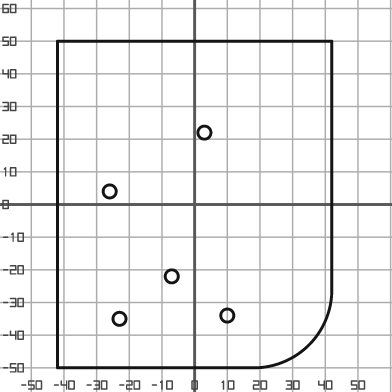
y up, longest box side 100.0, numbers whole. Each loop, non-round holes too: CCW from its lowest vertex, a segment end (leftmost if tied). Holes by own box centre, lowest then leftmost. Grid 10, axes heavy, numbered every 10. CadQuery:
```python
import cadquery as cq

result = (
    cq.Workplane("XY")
    .moveTo(-42.0, -50.0)
    .lineTo(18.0, -50.0)
    .threePointArc((35.0, -43.0), (42.0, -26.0))
    .lineTo(42.0, 50.0)
    .lineTo(-42.0, 50.0)
    .close()
    .moveTo(-23.0, -35.0)
    .circle(2.0)
    .moveTo(10.0, -34.0)
    .circle(2.0)
    .moveTo(-7.0, -22.0)
    .circle(2.0)
    .moveTo(-26.0, 4.0)
    .circle(2.0)
    .moveTo(3.0, 22.0)
    .circle(2.0)
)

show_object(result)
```